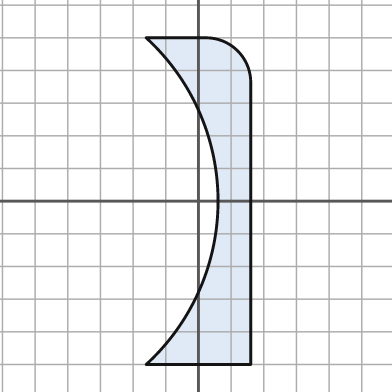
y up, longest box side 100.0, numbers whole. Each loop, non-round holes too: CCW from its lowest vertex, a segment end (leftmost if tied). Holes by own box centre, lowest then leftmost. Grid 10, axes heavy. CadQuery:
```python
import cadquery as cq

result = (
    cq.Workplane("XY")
    .moveTo(-16.0, -50.0)
    .lineTo(16.0, -50.0)
    .lineTo(16.0, 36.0)
    .threePointArc((12.0, 46.0), (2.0, 50.0))
    .lineTo(-16.0, 50.0)
    .threePointArc((6.0, 0.0), (-16.0, -50.0))
    .close()
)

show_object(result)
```